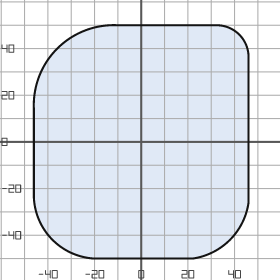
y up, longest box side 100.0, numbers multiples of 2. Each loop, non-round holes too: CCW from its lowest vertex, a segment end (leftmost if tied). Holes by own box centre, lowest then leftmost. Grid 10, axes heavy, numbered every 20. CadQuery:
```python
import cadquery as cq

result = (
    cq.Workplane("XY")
    .moveTo(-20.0, -50.0)
    .lineTo(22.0, -50.0)
    .threePointArc((38.0, -42.0), (46.0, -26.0))
    .lineTo(46.0, 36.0)
    .threePointArc((42.0, 46.0), (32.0, 50.0))
    .lineTo(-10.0, 50.0)
    .threePointArc((-36.0, 40.0), (-46.0, 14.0))
    .lineTo(-46.0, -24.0)
    .threePointArc((-38.0, -42.0), (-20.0, -50.0))
    .close()
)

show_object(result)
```